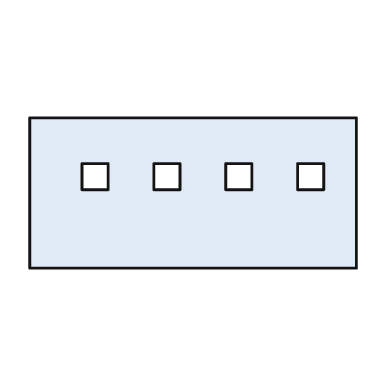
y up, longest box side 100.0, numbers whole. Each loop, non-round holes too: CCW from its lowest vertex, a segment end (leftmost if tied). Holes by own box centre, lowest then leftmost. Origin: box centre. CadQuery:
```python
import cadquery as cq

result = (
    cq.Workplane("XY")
    .moveTo(-50.0, -23.0)
    .lineTo(50.0, -23.0)
    .lineTo(50.0, 23.0)
    .lineTo(-50.0, 23.0)
    .close()
    .moveTo(-34.0, 1.0)
    .lineTo(-26.0, 1.0)
    .lineTo(-26.0, 9.0)
    .lineTo(-34.0, 9.0)
    .close()
    .moveTo(-12.0, 1.0)
    .lineTo(-4.0, 1.0)
    .lineTo(-4.0, 9.0)
    .lineTo(-12.0, 9.0)
    .close()
    .moveTo(10.0, 1.0)
    .lineTo(18.0, 1.0)
    .lineTo(18.0, 9.0)
    .lineTo(10.0, 9.0)
    .close()
    .moveTo(32.0, 1.0)
    .lineTo(40.0, 1.0)
    .lineTo(40.0, 9.0)
    .lineTo(32.0, 9.0)
    .close()
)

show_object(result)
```